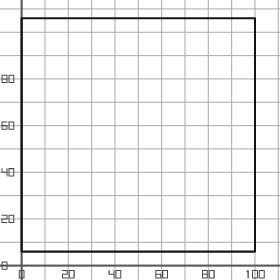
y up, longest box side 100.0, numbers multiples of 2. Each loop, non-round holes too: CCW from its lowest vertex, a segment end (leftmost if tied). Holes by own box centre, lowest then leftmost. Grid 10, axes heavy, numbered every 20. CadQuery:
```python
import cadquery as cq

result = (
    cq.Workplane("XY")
    .moveTo(0.0, 6.0)
    .lineTo(100.0, 6.0)
    .lineTo(100.0, 106.0)
    .lineTo(0.0, 106.0)
    .close()
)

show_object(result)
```